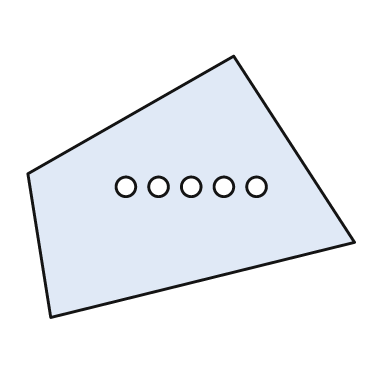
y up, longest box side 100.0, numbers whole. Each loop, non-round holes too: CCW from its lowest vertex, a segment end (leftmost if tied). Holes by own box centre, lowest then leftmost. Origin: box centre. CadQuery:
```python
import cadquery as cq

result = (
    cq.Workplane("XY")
    .moveTo(-43.0, -40.0)
    .lineTo(50.0, -17.0)
    .lineTo(13.0, 40.0)
    .lineTo(-50.0, 4.0)
    .close()
    .moveTo(-20.0, 0.0)
    .circle(3.0)
    .moveTo(-10.0, 0.0)
    .circle(3.0)
    .moveTo(0.0, 0.0)
    .circle(3.0)
    .moveTo(10.0, 0.0)
    .circle(3.0)
    .moveTo(20.0, 0.0)
    .circle(3.0)
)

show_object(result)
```